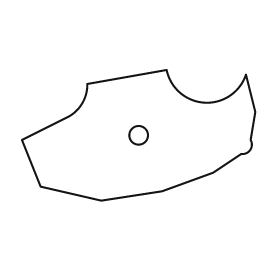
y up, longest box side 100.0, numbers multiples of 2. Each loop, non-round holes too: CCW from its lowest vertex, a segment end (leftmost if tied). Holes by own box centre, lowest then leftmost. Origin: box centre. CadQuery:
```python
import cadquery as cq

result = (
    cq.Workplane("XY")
    .moveTo(-16.0, -28.0)
    .lineTo(10.0, -24.0)
    .lineTo(32.0, -16.0)
    .lineTo(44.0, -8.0)
    .threePointArc((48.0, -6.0), (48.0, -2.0))
    .lineTo(50.0, 10.0)
    .lineTo(46.0, 26.0)
    .threePointArc((28.0, 14.0), (12.0, 28.0))
    .lineTo(-22.0, 22.0)
    .threePointArc((-24.0, 14.0), (-30.0, 8.0))
    .lineTo(-50.0, -2.0)
    .lineTo(-42.0, -22.0)
    .close()
    .moveTo(0.0, 0.0)
    .circle(4.0)
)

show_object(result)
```